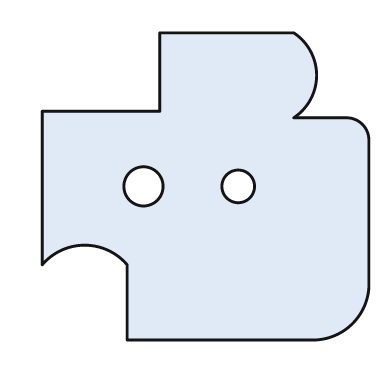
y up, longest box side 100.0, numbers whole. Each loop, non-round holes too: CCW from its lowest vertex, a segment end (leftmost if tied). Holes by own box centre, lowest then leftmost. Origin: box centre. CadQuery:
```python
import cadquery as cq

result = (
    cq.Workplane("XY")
    .moveTo(-24.0, -47.0)
    .lineTo(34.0, -47.0)
    .threePointArc((45.0, -42.0), (50.0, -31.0))
    .lineTo(50.0, 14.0)
    .threePointArc((48.0, 19.0), (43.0, 21.0))
    .lineTo(27.0, 21.0)
    .threePointArc((34.0, 34.0), (27.0, 47.0))
    .lineTo(-14.0, 47.0)
    .lineTo(-14.0, 23.0)
    .lineTo(-50.0, 23.0)
    .lineTo(-50.0, -24.0)
    .threePointArc((-37.0, -18.0), (-24.0, -24.0))
    .close()
    .moveTo(-19.0, 0.0)
    .circle(6.0)
    .moveTo(10.0, 0.0)
    .circle(5.0)
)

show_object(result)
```